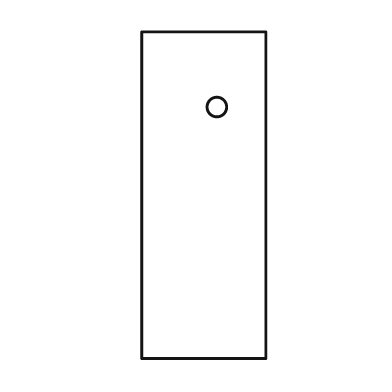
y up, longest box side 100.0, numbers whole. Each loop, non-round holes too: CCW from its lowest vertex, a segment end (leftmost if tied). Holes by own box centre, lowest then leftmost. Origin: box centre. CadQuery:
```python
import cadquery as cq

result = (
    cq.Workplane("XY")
    .moveTo(-19.0, -50.0)
    .lineTo(19.0, -50.0)
    .lineTo(19.0, 50.0)
    .lineTo(-19.0, 50.0)
    .close()
    .moveTo(4.0, 27.0)
    .circle(3.0)
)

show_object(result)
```